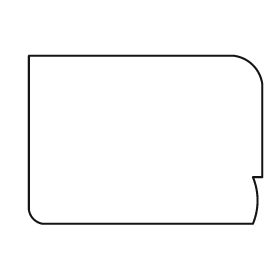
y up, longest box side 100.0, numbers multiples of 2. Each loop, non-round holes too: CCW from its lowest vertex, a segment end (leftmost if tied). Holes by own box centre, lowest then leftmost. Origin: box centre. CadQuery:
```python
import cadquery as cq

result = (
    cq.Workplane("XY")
    .moveTo(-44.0, -36.0)
    .lineTo(46.0, -36.0)
    .threePointArc((48.0, -26.0), (46.0, -16.0))
    .lineTo(50.0, -16.0)
    .lineTo(50.0, 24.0)
    .threePointArc((46.0, 32.0), (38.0, 36.0))
    .lineTo(-50.0, 36.0)
    .lineTo(-50.0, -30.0)
    .threePointArc((-48.0, -34.0), (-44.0, -36.0))
    .close()
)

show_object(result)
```